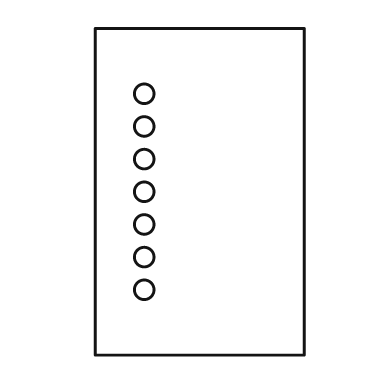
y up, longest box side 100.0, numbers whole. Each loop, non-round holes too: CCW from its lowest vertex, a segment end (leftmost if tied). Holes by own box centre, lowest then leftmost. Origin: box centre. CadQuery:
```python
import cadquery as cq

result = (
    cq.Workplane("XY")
    .moveTo(-32.0, -50.0)
    .lineTo(32.0, -50.0)
    .lineTo(32.0, 50.0)
    .lineTo(-32.0, 50.0)
    .close()
    .moveTo(-17.0, -30.0)
    .circle(3.0)
    .moveTo(-17.0, -20.0)
    .circle(3.0)
    .moveTo(-17.0, -10.0)
    .circle(3.0)
    .moveTo(-17.0, 0.0)
    .circle(3.0)
    .moveTo(-17.0, 10.0)
    .circle(3.0)
    .moveTo(-17.0, 20.0)
    .circle(3.0)
    .moveTo(-17.0, 30.0)
    .circle(3.0)
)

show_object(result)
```